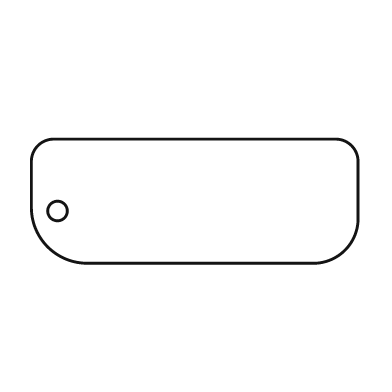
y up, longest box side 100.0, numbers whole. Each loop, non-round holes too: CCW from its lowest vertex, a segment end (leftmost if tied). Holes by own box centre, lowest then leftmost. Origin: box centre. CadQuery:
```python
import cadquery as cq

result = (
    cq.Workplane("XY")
    .moveTo(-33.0, -19.0)
    .lineTo(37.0, -19.0)
    .threePointArc((46.0, -15.0), (50.0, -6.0))
    .lineTo(50.0, 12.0)
    .threePointArc((48.0, 17.0), (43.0, 19.0))
    .lineTo(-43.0, 19.0)
    .threePointArc((-48.0, 17.0), (-50.0, 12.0))
    .lineTo(-50.0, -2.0)
    .threePointArc((-45.0, -14.0), (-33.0, -19.0))
    .close()
    .moveTo(-42.0, -3.0)
    .circle(3.0)
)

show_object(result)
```